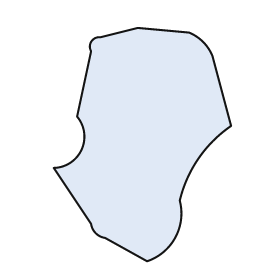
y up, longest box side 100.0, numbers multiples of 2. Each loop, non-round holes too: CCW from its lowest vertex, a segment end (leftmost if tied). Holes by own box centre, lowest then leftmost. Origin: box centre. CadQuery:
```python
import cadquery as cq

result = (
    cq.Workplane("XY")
    .moveTo(2.0, -50.0)
    .threePointArc((14.0, -40.0), (16.0, -24.0))
    .threePointArc((24.0, -6.0), (38.0, 8.0))
    .lineTo(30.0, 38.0)
    .threePointArc((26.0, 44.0), (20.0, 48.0))
    .lineTo(-2.0, 50.0)
    .lineTo(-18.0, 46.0)
    .threePointArc((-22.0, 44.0), (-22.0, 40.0))
    .lineTo(-28.0, 12.0)
    .threePointArc((-26.0, -2.0), (-38.0, -10.0))
    .lineTo(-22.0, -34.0)
    .threePointArc((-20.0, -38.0), (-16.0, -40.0))
    .close()
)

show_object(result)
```